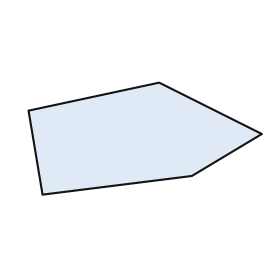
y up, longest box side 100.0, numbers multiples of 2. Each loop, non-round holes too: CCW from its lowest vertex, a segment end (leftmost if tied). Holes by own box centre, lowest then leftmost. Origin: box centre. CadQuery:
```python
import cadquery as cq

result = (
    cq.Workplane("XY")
    .moveTo(-44.0, -24.0)
    .lineTo(20.0, -16.0)
    .lineTo(50.0, 2.0)
    .lineTo(6.0, 24.0)
    .lineTo(-50.0, 12.0)
    .close()
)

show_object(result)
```